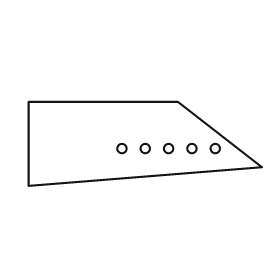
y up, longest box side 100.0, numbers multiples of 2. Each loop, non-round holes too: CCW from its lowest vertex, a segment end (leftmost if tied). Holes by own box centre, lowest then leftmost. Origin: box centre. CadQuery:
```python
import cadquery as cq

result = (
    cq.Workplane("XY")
    .moveTo(-50.0, -18.0)
    .lineTo(50.0, -10.0)
    .lineTo(14.0, 18.0)
    .lineTo(-50.0, 18.0)
    .close()
    .moveTo(-10.0, -2.0)
    .circle(2.0)
    .moveTo(0.0, -2.0)
    .circle(2.0)
    .moveTo(10.0, -2.0)
    .circle(2.0)
    .moveTo(20.0, -2.0)
    .circle(2.0)
    .moveTo(30.0, -2.0)
    .circle(2.0)
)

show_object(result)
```